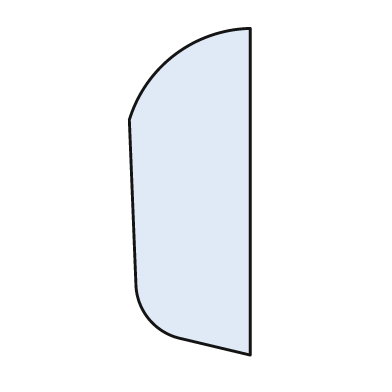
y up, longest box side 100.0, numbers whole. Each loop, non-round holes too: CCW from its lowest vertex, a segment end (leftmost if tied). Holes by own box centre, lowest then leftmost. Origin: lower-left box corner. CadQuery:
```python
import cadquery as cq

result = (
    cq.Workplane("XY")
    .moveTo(37.0, 0.0)
    .lineTo(37.0, 100.0)
    .threePointArc((14.0, 92.0), (0.0, 72.0))
    .lineTo(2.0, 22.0)
    .threePointArc((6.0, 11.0), (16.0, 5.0))
    .close()
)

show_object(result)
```